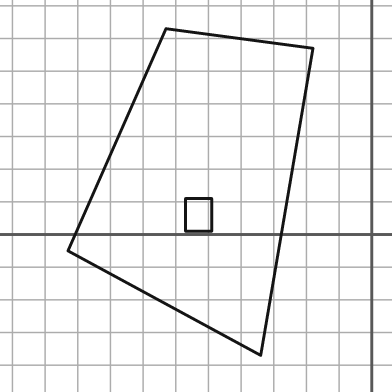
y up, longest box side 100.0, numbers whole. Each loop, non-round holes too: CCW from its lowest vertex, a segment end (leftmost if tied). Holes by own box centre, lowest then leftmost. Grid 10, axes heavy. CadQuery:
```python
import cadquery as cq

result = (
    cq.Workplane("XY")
    .moveTo(-34.0, -37.0)
    .lineTo(-18.0, 57.0)
    .lineTo(-63.0, 63.0)
    .lineTo(-93.0, -5.0)
    .close()
    .moveTo(-57.0, 1.0)
    .lineTo(-49.0, 1.0)
    .lineTo(-49.0, 11.0)
    .lineTo(-57.0, 11.0)
    .close()
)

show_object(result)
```